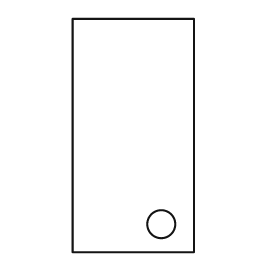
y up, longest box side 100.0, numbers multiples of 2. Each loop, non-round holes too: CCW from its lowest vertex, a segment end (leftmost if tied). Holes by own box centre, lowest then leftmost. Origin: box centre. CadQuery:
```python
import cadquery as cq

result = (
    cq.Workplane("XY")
    .moveTo(-26.0, -50.0)
    .lineTo(26.0, -50.0)
    .lineTo(26.0, 50.0)
    .lineTo(-26.0, 50.0)
    .close()
    .moveTo(12.0, -38.0)
    .circle(6.0)
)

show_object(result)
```